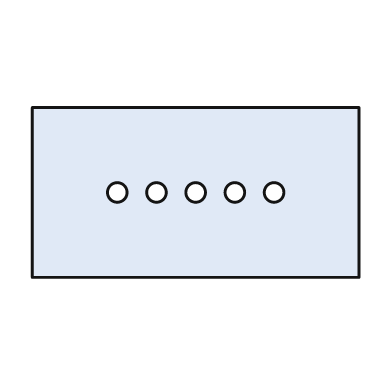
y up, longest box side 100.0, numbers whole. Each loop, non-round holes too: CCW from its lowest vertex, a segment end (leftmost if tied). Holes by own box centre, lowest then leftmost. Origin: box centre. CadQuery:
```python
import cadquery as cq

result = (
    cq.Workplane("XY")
    .moveTo(-50.0, -26.0)
    .lineTo(50.0, -26.0)
    .lineTo(50.0, 26.0)
    .lineTo(-50.0, 26.0)
    .close()
    .moveTo(-24.0, 0.0)
    .circle(3.0)
    .moveTo(-12.0, 0.0)
    .circle(3.0)
    .moveTo(0.0, 0.0)
    .circle(3.0)
    .moveTo(12.0, 0.0)
    .circle(3.0)
    .moveTo(24.0, 0.0)
    .circle(3.0)
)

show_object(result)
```